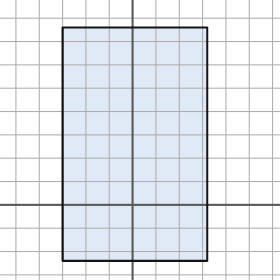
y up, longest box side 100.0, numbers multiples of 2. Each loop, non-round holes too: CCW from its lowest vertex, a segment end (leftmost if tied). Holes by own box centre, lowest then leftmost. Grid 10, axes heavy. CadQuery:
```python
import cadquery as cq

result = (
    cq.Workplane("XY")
    .moveTo(-30.0, -24.0)
    .lineTo(32.0, -24.0)
    .lineTo(32.0, 76.0)
    .lineTo(-30.0, 76.0)
    .close()
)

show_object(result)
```